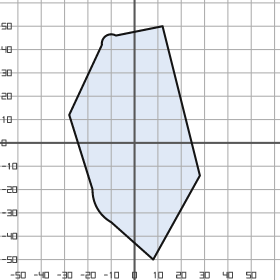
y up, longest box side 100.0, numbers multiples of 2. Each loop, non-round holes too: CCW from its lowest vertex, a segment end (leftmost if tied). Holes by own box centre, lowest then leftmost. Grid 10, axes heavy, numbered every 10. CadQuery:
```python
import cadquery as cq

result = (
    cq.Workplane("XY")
    .moveTo(8.0, -50.0)
    .lineTo(28.0, -14.0)
    .lineTo(12.0, 50.0)
    .lineTo(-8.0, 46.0)
    .threePointArc((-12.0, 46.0), (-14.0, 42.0))
    .lineTo(-28.0, 12.0)
    .lineTo(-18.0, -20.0)
    .threePointArc((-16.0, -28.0), (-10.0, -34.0))
    .close()
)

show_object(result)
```